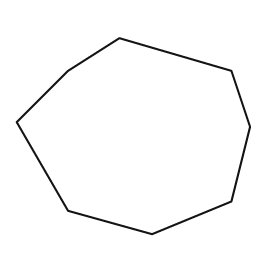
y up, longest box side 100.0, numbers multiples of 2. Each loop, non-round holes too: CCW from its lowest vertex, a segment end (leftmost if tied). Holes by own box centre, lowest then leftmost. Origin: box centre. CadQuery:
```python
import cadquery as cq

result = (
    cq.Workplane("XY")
    .moveTo(8.0, -42.0)
    .lineTo(42.0, -28.0)
    .lineTo(50.0, 4.0)
    .lineTo(42.0, 28.0)
    .lineTo(-6.0, 42.0)
    .lineTo(-28.0, 28.0)
    .lineTo(-50.0, 6.0)
    .lineTo(-28.0, -32.0)
    .close()
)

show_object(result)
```